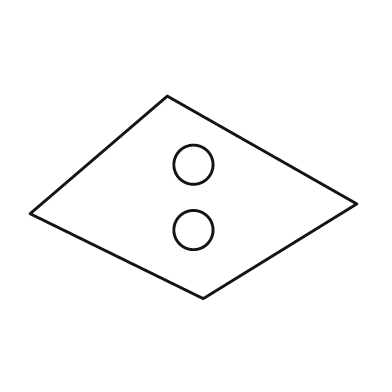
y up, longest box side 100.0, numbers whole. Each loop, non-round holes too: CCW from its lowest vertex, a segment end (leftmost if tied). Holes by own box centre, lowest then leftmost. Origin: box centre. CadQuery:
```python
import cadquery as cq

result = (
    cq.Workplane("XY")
    .moveTo(3.0, -31.0)
    .lineTo(50.0, -2.0)
    .lineTo(-8.0, 31.0)
    .lineTo(-50.0, -5.0)
    .close()
    .moveTo(0.0, -10.0)
    .circle(6.0)
    .moveTo(0.0, 10.0)
    .circle(6.0)
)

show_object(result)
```